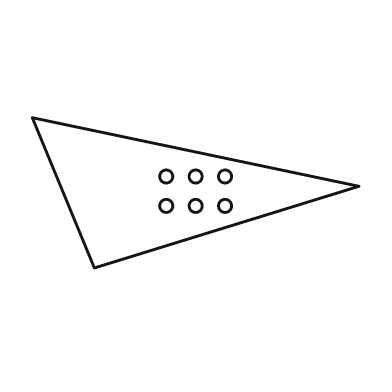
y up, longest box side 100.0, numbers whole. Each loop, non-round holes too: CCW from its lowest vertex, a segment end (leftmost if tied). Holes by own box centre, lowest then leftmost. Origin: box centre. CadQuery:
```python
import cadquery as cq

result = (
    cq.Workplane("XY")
    .moveTo(-31.0, -23.0)
    .lineTo(50.0, 2.0)
    .lineTo(-50.0, 23.0)
    .close()
    .moveTo(-9.0, -4.0)
    .circle(2.0)
    .moveTo(0.0, -4.0)
    .circle(2.0)
    .moveTo(9.0, -4.0)
    .circle(2.0)
    .moveTo(-9.0, 5.0)
    .circle(2.0)
    .moveTo(0.0, 5.0)
    .circle(2.0)
    .moveTo(9.0, 5.0)
    .circle(2.0)
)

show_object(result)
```